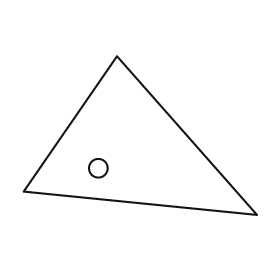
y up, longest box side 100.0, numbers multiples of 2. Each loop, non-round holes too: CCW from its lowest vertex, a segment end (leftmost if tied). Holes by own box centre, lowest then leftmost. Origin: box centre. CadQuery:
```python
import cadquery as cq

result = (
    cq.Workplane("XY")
    .moveTo(50.0, -34.0)
    .lineTo(-10.0, 34.0)
    .lineTo(-50.0, -24.0)
    .close()
    .moveTo(-18.0, -14.0)
    .circle(4.0)
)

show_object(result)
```